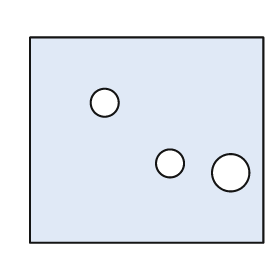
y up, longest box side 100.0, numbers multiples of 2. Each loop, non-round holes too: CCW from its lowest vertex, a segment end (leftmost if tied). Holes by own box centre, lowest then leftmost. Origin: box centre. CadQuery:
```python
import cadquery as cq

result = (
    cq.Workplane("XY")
    .moveTo(-50.0, -44.0)
    .lineTo(50.0, -44.0)
    .lineTo(50.0, 44.0)
    .lineTo(-50.0, 44.0)
    .close()
    .moveTo(36.0, -14.0)
    .circle(8.0)
    .moveTo(10.0, -10.0)
    .circle(6.0)
    .moveTo(-18.0, 16.0)
    .circle(6.0)
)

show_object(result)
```